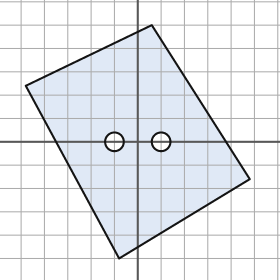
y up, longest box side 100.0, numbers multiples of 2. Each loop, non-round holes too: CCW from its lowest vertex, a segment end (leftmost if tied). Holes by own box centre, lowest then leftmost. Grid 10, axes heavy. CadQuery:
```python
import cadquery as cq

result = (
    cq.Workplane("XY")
    .moveTo(-8.0, -50.0)
    .lineTo(48.0, -16.0)
    .lineTo(6.0, 50.0)
    .lineTo(-48.0, 24.0)
    .close()
    .moveTo(-10.0, 0.0)
    .circle(4.0)
    .moveTo(10.0, 0.0)
    .circle(4.0)
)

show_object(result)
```